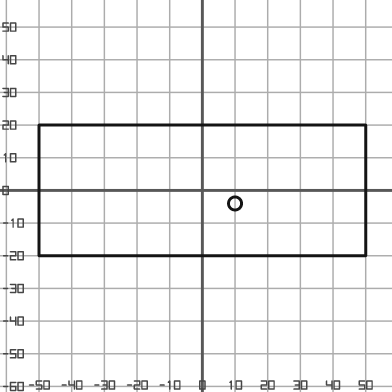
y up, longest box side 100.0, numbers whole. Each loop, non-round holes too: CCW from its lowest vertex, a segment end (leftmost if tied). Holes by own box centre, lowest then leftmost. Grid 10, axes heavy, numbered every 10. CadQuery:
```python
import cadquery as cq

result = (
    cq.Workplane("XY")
    .moveTo(-50.0, -20.0)
    .lineTo(50.0, -20.0)
    .lineTo(50.0, 20.0)
    .lineTo(-50.0, 20.0)
    .close()
    .moveTo(10.0, -4.0)
    .circle(2.0)
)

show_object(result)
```